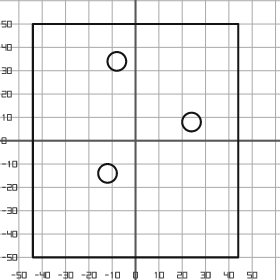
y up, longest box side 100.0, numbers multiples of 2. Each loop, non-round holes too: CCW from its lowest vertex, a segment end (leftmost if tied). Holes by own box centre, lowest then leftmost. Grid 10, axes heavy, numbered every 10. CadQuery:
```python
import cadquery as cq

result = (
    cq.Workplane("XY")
    .moveTo(-44.0, -50.0)
    .lineTo(44.0, -50.0)
    .lineTo(44.0, 50.0)
    .lineTo(-44.0, 50.0)
    .close()
    .moveTo(-12.0, -14.0)
    .circle(4.0)
    .moveTo(24.0, 8.0)
    .circle(4.0)
    .moveTo(-8.0, 34.0)
    .circle(4.0)
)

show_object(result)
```